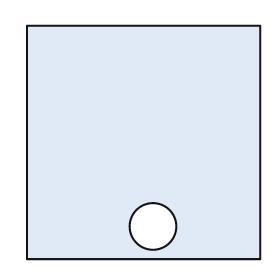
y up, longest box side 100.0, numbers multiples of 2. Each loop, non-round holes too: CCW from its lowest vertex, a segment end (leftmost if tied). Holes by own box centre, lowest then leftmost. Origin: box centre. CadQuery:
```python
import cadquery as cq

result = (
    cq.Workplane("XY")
    .moveTo(-50.0, -50.0)
    .lineTo(50.0, -50.0)
    .lineTo(50.0, 50.0)
    .lineTo(-50.0, 50.0)
    .close()
    .moveTo(4.0, -36.0)
    .circle(10.0)
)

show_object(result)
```